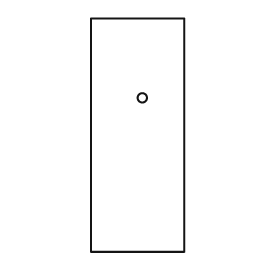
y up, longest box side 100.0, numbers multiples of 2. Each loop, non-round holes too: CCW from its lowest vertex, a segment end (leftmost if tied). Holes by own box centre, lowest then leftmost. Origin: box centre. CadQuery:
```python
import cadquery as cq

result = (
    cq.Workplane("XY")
    .moveTo(-20.0, -50.0)
    .lineTo(20.0, -50.0)
    .lineTo(20.0, 50.0)
    .lineTo(-20.0, 50.0)
    .close()
    .moveTo(2.0, 16.0)
    .circle(2.0)
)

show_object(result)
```